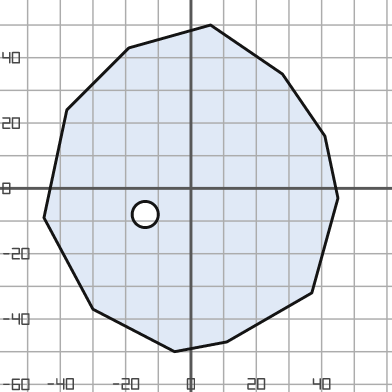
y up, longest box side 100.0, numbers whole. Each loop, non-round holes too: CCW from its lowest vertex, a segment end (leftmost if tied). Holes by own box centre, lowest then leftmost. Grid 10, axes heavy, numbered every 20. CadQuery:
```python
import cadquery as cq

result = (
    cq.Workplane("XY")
    .moveTo(-5.0, -50.0)
    .lineTo(11.0, -47.0)
    .lineTo(37.0, -32.0)
    .lineTo(45.0, -3.0)
    .lineTo(41.0, 16.0)
    .lineTo(28.0, 35.0)
    .lineTo(6.0, 50.0)
    .lineTo(-19.0, 43.0)
    .lineTo(-38.0, 24.0)
    .lineTo(-45.0, -9.0)
    .lineTo(-30.0, -37.0)
    .close()
    .moveTo(-14.0, -8.0)
    .circle(4.0)
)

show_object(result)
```